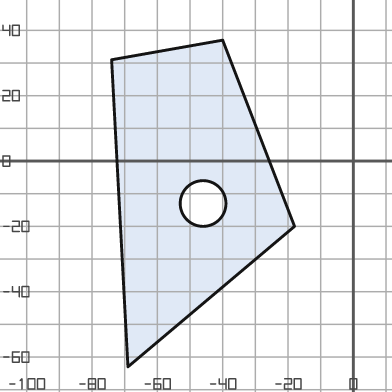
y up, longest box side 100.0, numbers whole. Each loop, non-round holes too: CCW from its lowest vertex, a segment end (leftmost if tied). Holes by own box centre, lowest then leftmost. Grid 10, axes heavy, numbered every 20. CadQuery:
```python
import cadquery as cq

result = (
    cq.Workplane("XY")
    .moveTo(-69.0, -63.0)
    .lineTo(-18.0, -20.0)
    .lineTo(-40.0, 37.0)
    .lineTo(-74.0, 31.0)
    .close()
    .moveTo(-46.0, -13.0)
    .circle(7.0)
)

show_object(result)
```